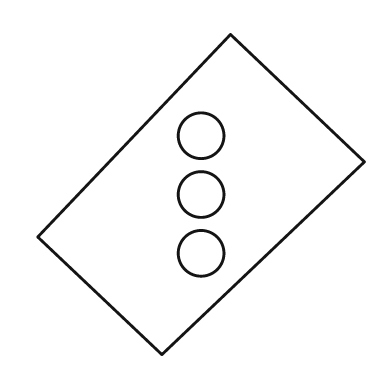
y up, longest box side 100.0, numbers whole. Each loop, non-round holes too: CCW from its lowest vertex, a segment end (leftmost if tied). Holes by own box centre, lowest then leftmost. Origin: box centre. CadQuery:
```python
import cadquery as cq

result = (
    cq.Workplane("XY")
    .moveTo(-12.0, -49.0)
    .lineTo(50.0, 10.0)
    .lineTo(9.0, 49.0)
    .lineTo(-50.0, -13.0)
    .close()
    .moveTo(0.0, -18.0)
    .circle(7.0)
    .moveTo(0.0, 0.0)
    .circle(7.0)
    .moveTo(0.0, 18.0)
    .circle(7.0)
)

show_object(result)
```